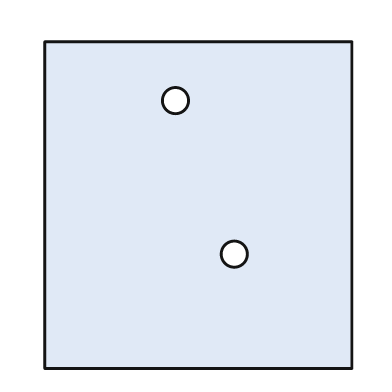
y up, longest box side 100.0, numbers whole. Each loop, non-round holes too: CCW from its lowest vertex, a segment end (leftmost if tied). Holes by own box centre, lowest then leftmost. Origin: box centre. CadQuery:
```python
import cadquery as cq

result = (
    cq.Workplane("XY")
    .moveTo(-47.0, -50.0)
    .lineTo(47.0, -50.0)
    .lineTo(47.0, 50.0)
    .lineTo(-47.0, 50.0)
    .close()
    .moveTo(11.0, -15.0)
    .circle(4.0)
    .moveTo(-7.0, 32.0)
    .circle(4.0)
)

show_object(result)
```